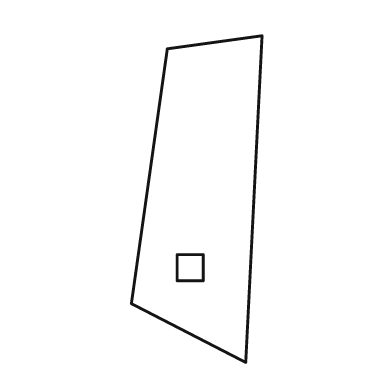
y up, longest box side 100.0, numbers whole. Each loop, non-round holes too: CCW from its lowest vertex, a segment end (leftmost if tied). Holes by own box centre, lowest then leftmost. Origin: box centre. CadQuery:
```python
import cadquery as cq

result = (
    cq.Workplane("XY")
    .moveTo(15.0, -50.0)
    .lineTo(20.0, 50.0)
    .lineTo(-9.0, 46.0)
    .lineTo(-20.0, -32.0)
    .close()
    .moveTo(-6.0, -25.0)
    .lineTo(2.0, -25.0)
    .lineTo(2.0, -17.0)
    .lineTo(-6.0, -17.0)
    .close()
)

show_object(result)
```